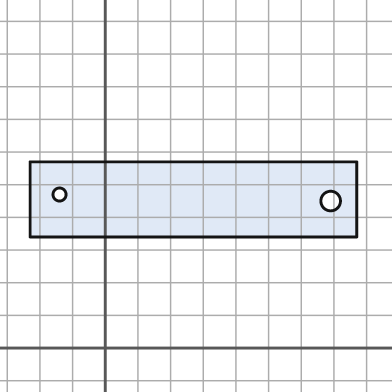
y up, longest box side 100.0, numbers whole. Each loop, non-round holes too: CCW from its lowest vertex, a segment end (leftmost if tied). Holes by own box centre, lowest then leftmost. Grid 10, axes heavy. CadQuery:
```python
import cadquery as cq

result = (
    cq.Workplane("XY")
    .moveTo(-23.0, 34.0)
    .lineTo(77.0, 34.0)
    .lineTo(77.0, 57.0)
    .lineTo(-23.0, 57.0)
    .close()
    .moveTo(69.0, 45.0)
    .circle(3.0)
    .moveTo(-14.0, 47.0)
    .circle(2.0)
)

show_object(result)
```